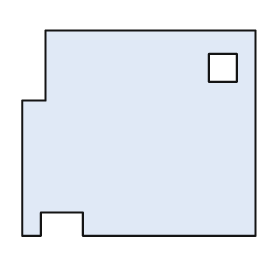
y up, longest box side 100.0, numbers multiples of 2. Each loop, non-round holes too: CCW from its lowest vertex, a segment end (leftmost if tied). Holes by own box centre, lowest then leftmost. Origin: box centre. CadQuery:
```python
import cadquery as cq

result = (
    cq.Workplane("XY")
    .moveTo(-50.0, -44.0)
    .lineTo(-42.0, -44.0)
    .lineTo(-42.0, -34.0)
    .lineTo(-24.0, -34.0)
    .lineTo(-24.0, -44.0)
    .lineTo(50.0, -44.0)
    .lineTo(50.0, 44.0)
    .lineTo(-40.0, 44.0)
    .lineTo(-40.0, 14.0)
    .lineTo(-50.0, 14.0)
    .close()
    .moveTo(30.0, 22.0)
    .lineTo(42.0, 22.0)
    .lineTo(42.0, 34.0)
    .lineTo(30.0, 34.0)
    .close()
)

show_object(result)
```